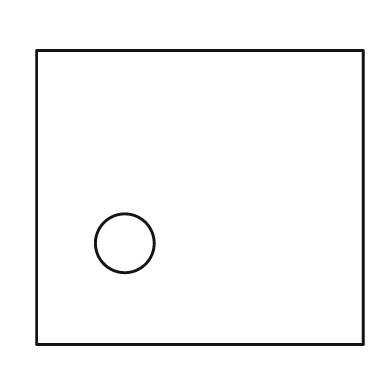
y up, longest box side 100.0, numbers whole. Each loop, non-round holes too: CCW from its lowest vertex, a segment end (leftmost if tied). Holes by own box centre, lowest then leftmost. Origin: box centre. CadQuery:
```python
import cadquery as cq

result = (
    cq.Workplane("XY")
    .moveTo(-50.0, -45.0)
    .lineTo(50.0, -45.0)
    .lineTo(50.0, 45.0)
    .lineTo(-50.0, 45.0)
    .close()
    .moveTo(-23.0, -14.0)
    .circle(9.0)
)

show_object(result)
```